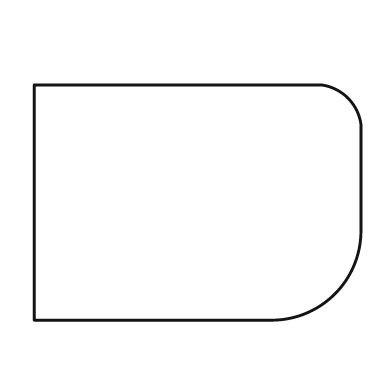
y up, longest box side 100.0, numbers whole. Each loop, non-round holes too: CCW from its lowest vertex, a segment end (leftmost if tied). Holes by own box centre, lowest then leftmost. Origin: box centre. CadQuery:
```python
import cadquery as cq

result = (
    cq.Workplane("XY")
    .moveTo(-50.0, -36.0)
    .lineTo(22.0, -36.0)
    .threePointArc((42.0, -28.0), (50.0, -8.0))
    .lineTo(50.0, 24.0)
    .threePointArc((46.0, 32.0), (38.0, 36.0))
    .lineTo(-50.0, 36.0)
    .close()
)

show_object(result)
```